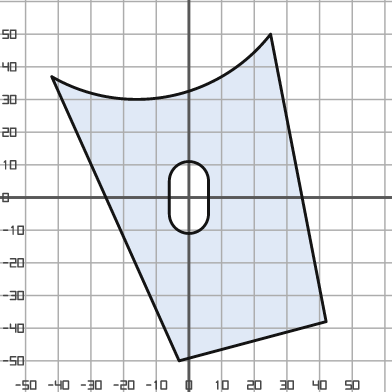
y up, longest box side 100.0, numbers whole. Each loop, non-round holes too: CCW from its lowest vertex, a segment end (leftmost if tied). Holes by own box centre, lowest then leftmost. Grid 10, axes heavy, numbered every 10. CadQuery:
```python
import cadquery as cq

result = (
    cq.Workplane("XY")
    .moveTo(-3.0, -50.0)
    .lineTo(42.0, -38.0)
    .lineTo(25.0, 50.0)
    .threePointArc((-6.0, 31.0), (-42.0, 37.0))
    .close()
    .moveTo(-6.0, -5.0)
    .threePointArc((0.0, -11.0), (6.0, -5.0))
    .lineTo(6.0, 5.0)
    .threePointArc((0.0, 11.0), (-6.0, 5.0))
    .close()
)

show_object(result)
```